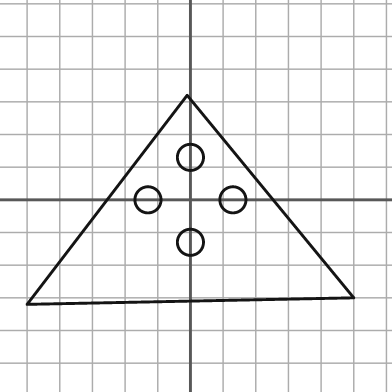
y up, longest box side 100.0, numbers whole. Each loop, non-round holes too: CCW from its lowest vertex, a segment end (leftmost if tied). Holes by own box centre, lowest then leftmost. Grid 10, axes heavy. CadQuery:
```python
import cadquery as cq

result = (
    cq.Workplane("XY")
    .moveTo(-50.0, -32.0)
    .lineTo(50.0, -30.0)
    .lineTo(-1.0, 32.0)
    .close()
    .moveTo(0.0, -13.0)
    .circle(4.0)
    .moveTo(-13.0, 0.0)
    .circle(4.0)
    .moveTo(13.0, 0.0)
    .circle(4.0)
    .moveTo(0.0, 13.0)
    .circle(4.0)
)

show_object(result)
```